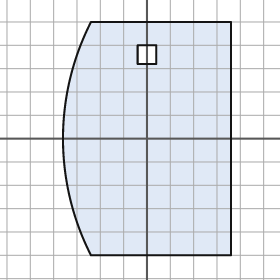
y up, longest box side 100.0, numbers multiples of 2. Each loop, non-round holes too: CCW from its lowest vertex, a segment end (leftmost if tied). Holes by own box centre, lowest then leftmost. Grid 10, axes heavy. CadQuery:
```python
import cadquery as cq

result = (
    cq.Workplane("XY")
    .moveTo(-24.0, -50.0)
    .lineTo(36.0, -50.0)
    .lineTo(36.0, 50.0)
    .lineTo(-24.0, 50.0)
    .threePointArc((-36.0, 0.0), (-24.0, -50.0))
    .close()
    .moveTo(-4.0, 32.0)
    .lineTo(4.0, 32.0)
    .lineTo(4.0, 40.0)
    .lineTo(-4.0, 40.0)
    .close()
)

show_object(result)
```